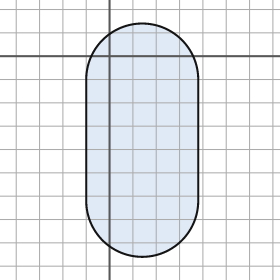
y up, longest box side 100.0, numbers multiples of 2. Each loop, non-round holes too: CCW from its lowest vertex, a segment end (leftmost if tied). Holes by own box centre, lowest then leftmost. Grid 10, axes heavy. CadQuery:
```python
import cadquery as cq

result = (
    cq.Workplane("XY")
    .moveTo(-10.0, -62.0)
    .threePointArc((14.0, -86.0), (38.0, -62.0))
    .lineTo(38.0, -10.0)
    .threePointArc((14.0, 14.0), (-10.0, -10.0))
    .close()
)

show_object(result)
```